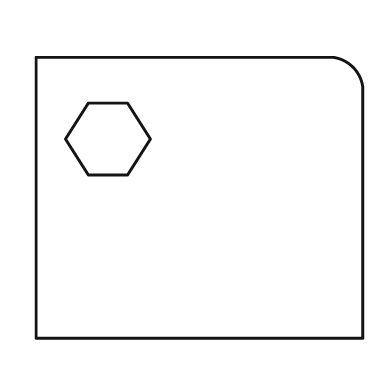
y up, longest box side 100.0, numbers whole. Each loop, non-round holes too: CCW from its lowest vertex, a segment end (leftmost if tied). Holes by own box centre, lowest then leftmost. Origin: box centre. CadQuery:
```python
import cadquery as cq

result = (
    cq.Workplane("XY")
    .moveTo(-50.0, -43.0)
    .lineTo(50.0, -43.0)
    .lineTo(50.0, 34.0)
    .threePointArc((47.0, 40.0), (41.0, 43.0))
    .lineTo(-50.0, 43.0)
    .close()
    .moveTo(-34.0, 7.0)
    .lineTo(-22.0, 7.0)
    .lineTo(-15.0, 18.0)
    .lineTo(-22.0, 29.0)
    .lineTo(-34.0, 29.0)
    .lineTo(-41.0, 18.0)
    .close()
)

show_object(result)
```